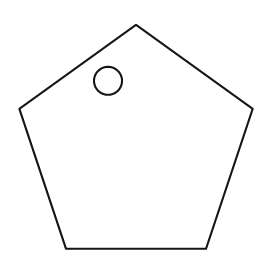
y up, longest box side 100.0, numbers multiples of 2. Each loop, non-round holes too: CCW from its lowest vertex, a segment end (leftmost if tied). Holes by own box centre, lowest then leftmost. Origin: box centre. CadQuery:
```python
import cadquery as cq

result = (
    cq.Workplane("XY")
    .moveTo(-30.0, -48.0)
    .lineTo(30.0, -48.0)
    .lineTo(50.0, 12.0)
    .lineTo(0.0, 48.0)
    .lineTo(-50.0, 12.0)
    .close()
    .moveTo(-12.0, 24.0)
    .circle(6.0)
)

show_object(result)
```